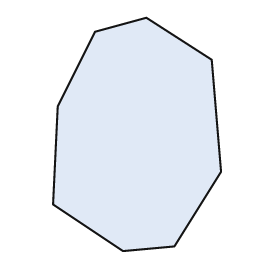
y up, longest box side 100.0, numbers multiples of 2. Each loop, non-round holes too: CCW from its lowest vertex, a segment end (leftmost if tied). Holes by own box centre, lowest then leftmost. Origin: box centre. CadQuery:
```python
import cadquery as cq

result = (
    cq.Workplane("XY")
    .moveTo(-6.0, -50.0)
    .lineTo(16.0, -48.0)
    .lineTo(36.0, -16.0)
    .lineTo(32.0, 32.0)
    .lineTo(4.0, 50.0)
    .lineTo(-18.0, 44.0)
    .lineTo(-34.0, 12.0)
    .lineTo(-36.0, -30.0)
    .close()
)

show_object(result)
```